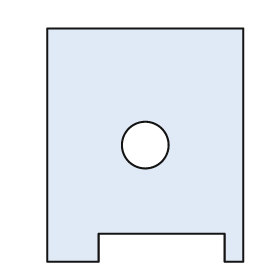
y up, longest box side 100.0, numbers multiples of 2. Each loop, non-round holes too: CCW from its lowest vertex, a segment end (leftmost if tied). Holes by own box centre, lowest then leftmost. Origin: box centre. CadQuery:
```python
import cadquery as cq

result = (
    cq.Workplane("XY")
    .moveTo(-42.0, -50.0)
    .lineTo(-20.0, -50.0)
    .lineTo(-20.0, -38.0)
    .lineTo(34.0, -38.0)
    .lineTo(34.0, -50.0)
    .lineTo(42.0, -50.0)
    .lineTo(42.0, 50.0)
    .lineTo(-42.0, 50.0)
    .close()
    .moveTo(0.0, 0.0)
    .circle(10.0)
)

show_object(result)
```